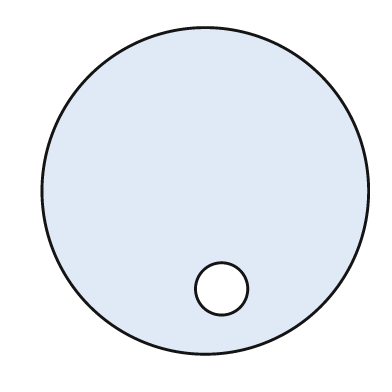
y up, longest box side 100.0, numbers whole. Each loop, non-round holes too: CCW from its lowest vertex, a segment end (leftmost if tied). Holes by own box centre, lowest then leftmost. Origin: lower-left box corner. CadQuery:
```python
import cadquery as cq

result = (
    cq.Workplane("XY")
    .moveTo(50.0, 50.0)
    .circle(50.0)
    .moveTo(55.0, 20.0)
    .circle(8.0)
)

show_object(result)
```